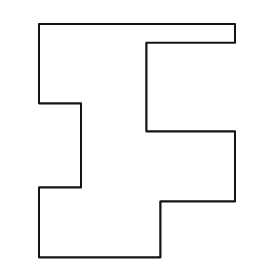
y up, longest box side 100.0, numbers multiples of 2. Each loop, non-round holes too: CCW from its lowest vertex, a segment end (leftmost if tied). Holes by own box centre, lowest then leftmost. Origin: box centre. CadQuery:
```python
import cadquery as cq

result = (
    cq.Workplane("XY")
    .moveTo(-42.0, -50.0)
    .lineTo(10.0, -50.0)
    .lineTo(10.0, -26.0)
    .lineTo(42.0, -26.0)
    .lineTo(42.0, 4.0)
    .lineTo(4.0, 4.0)
    .lineTo(4.0, 42.0)
    .lineTo(42.0, 42.0)
    .lineTo(42.0, 50.0)
    .lineTo(-42.0, 50.0)
    .lineTo(-42.0, 16.0)
    .lineTo(-24.0, 16.0)
    .lineTo(-24.0, -20.0)
    .lineTo(-42.0, -20.0)
    .close()
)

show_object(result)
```